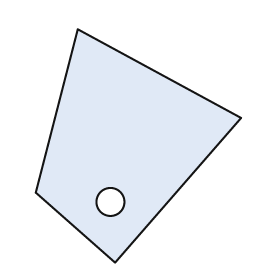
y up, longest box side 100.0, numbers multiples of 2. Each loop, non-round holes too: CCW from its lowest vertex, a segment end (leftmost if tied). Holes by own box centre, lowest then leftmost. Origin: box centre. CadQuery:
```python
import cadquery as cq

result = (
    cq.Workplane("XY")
    .moveTo(-10.0, -50.0)
    .lineTo(44.0, 12.0)
    .lineTo(-26.0, 50.0)
    .lineTo(-44.0, -20.0)
    .close()
    .moveTo(-12.0, -24.0)
    .circle(6.0)
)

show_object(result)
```